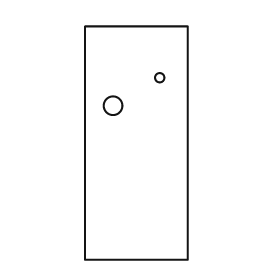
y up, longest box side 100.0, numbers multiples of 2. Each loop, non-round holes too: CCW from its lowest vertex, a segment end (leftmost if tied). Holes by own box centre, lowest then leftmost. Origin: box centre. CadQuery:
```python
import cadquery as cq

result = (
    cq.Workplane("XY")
    .moveTo(-22.0, -50.0)
    .lineTo(22.0, -50.0)
    .lineTo(22.0, 50.0)
    .lineTo(-22.0, 50.0)
    .close()
    .moveTo(-10.0, 16.0)
    .circle(4.0)
    .moveTo(10.0, 28.0)
    .circle(2.0)
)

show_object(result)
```